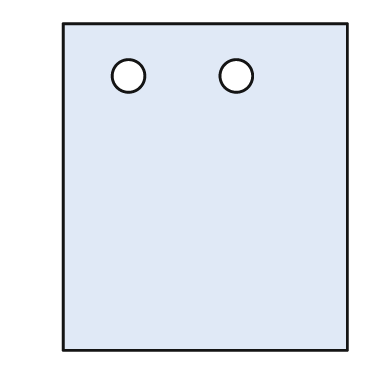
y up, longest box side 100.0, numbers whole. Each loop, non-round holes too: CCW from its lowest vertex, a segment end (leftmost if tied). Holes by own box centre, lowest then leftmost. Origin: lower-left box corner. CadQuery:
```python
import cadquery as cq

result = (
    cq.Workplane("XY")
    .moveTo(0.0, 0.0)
    .lineTo(87.0, 0.0)
    .lineTo(87.0, 100.0)
    .lineTo(0.0, 100.0)
    .close()
    .moveTo(20.0, 84.0)
    .circle(5.0)
    .moveTo(53.0, 84.0)
    .circle(5.0)
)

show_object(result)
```